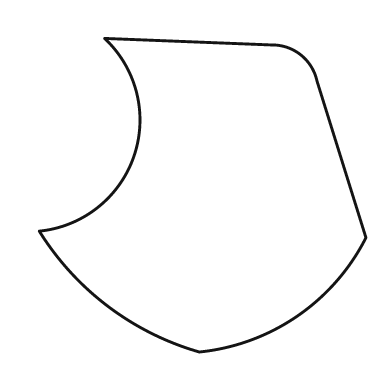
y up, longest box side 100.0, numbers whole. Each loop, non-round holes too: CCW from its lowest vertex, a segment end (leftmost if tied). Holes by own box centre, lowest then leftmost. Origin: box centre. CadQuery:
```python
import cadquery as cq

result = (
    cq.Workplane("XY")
    .moveTo(-1.0, -48.0)
    .threePointArc((29.0, -37.0), (50.0, -13.0))
    .lineTo(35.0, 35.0)
    .threePointArc((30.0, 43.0), (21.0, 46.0))
    .lineTo(-30.0, 48.0)
    .threePointArc((-21.0, 12.0), (-50.0, -11.0))
    .threePointArc((-29.0, -34.0), (-1.0, -48.0))
    .close()
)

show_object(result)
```